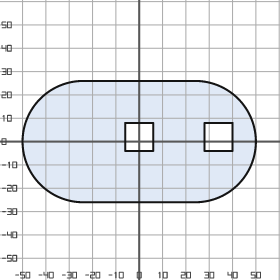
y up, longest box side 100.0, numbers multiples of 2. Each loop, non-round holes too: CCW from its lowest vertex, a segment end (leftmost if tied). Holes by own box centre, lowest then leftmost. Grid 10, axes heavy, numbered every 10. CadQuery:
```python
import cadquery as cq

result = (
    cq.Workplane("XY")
    .moveTo(-24.0, -26.0)
    .lineTo(24.0, -26.0)
    .threePointArc((50.0, 0.0), (24.0, 26.0))
    .lineTo(-24.0, 26.0)
    .threePointArc((-50.0, 0.0), (-24.0, -26.0))
    .close()
    .moveTo(-6.0, -4.0)
    .lineTo(6.0, -4.0)
    .lineTo(6.0, 8.0)
    .lineTo(-6.0, 8.0)
    .close()
    .moveTo(28.0, -4.0)
    .lineTo(40.0, -4.0)
    .lineTo(40.0, 8.0)
    .lineTo(28.0, 8.0)
    .close()
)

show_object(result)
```